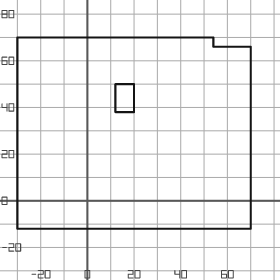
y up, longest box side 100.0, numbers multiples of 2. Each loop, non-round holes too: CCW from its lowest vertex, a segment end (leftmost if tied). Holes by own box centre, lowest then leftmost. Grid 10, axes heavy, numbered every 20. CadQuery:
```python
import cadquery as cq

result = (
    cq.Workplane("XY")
    .moveTo(-30.0, -12.0)
    .lineTo(70.0, -12.0)
    .lineTo(70.0, 66.0)
    .lineTo(54.0, 66.0)
    .lineTo(54.0, 70.0)
    .lineTo(-30.0, 70.0)
    .close()
    .moveTo(12.0, 38.0)
    .lineTo(20.0, 38.0)
    .lineTo(20.0, 50.0)
    .lineTo(12.0, 50.0)
    .close()
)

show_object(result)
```